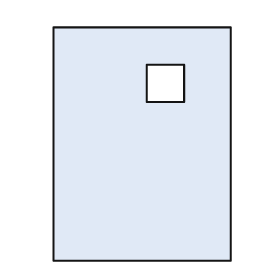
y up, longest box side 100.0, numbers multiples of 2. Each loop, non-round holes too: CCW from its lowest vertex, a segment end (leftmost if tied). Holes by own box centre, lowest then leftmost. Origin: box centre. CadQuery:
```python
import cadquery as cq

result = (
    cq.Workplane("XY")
    .moveTo(-38.0, -50.0)
    .lineTo(38.0, -50.0)
    .lineTo(38.0, 50.0)
    .lineTo(-38.0, 50.0)
    .close()
    .moveTo(2.0, 18.0)
    .lineTo(18.0, 18.0)
    .lineTo(18.0, 34.0)
    .lineTo(2.0, 34.0)
    .close()
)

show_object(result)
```